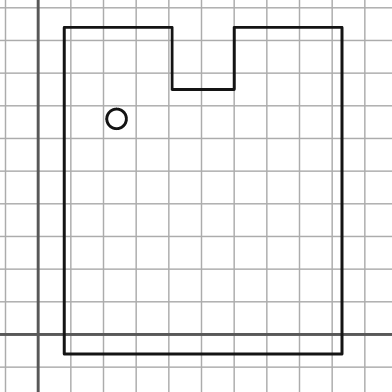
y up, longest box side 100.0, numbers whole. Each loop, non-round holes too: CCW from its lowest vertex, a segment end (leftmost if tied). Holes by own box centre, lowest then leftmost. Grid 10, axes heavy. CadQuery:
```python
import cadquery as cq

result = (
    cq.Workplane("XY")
    .moveTo(8.0, -6.0)
    .lineTo(93.0, -6.0)
    .lineTo(93.0, 94.0)
    .lineTo(60.0, 94.0)
    .lineTo(60.0, 75.0)
    .lineTo(41.0, 75.0)
    .lineTo(41.0, 94.0)
    .lineTo(8.0, 94.0)
    .close()
    .moveTo(24.0, 66.0)
    .circle(3.0)
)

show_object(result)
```